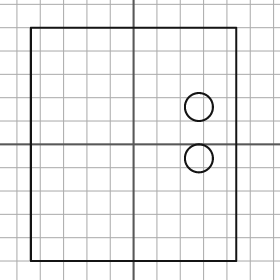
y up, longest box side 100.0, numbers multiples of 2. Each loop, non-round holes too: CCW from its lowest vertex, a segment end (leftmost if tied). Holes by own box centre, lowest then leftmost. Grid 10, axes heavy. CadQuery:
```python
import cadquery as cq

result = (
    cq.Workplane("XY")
    .moveTo(-44.0, -50.0)
    .lineTo(44.0, -50.0)
    .lineTo(44.0, 50.0)
    .lineTo(-44.0, 50.0)
    .close()
    .moveTo(28.0, -6.0)
    .circle(6.0)
    .moveTo(28.0, 16.0)
    .circle(6.0)
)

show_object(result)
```